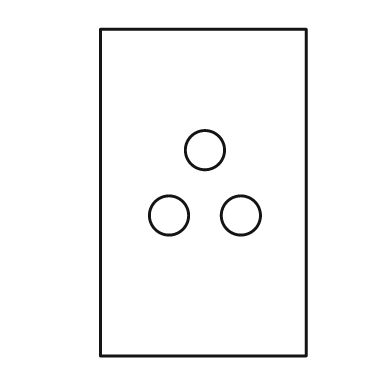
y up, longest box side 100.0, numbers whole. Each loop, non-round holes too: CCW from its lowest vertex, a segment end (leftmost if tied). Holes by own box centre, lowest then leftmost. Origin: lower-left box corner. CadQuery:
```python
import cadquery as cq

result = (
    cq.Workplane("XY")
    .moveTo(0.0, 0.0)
    .lineTo(63.0, 0.0)
    .lineTo(63.0, 100.0)
    .lineTo(0.0, 100.0)
    .close()
    .moveTo(21.0, 43.0)
    .circle(6.0)
    .moveTo(43.0, 43.0)
    .circle(6.0)
    .moveTo(32.0, 63.0)
    .circle(6.0)
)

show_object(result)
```